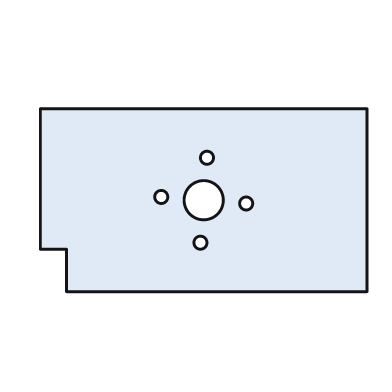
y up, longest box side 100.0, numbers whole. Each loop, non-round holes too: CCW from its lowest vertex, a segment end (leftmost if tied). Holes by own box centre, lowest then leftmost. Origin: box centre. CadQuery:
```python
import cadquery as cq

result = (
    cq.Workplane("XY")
    .moveTo(-42.0, -28.0)
    .lineTo(50.0, -28.0)
    .lineTo(50.0, 28.0)
    .lineTo(-50.0, 28.0)
    .lineTo(-50.0, -15.0)
    .lineTo(-42.0, -15.0)
    .close()
    .moveTo(-1.0, -13.0)
    .circle(2.0)
    .moveTo(13.0, -1.0)
    .circle(2.0)
    .moveTo(0.0, 0.0)
    .circle(6.0)
    .moveTo(-13.0, 1.0)
    .circle(2.0)
    .moveTo(1.0, 13.0)
    .circle(2.0)
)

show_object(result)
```